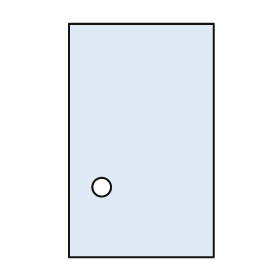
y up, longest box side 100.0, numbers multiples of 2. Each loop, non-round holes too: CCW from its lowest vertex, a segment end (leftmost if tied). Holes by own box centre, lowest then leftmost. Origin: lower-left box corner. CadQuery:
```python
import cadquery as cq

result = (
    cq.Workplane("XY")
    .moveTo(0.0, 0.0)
    .lineTo(62.0, 0.0)
    .lineTo(62.0, 100.0)
    .lineTo(0.0, 100.0)
    .close()
    .moveTo(14.0, 30.0)
    .circle(4.0)
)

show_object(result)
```